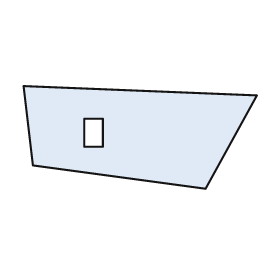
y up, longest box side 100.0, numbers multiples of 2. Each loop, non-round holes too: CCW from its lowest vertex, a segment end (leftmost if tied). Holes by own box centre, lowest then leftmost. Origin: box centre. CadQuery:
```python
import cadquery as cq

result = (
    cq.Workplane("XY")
    .moveTo(28.0, -22.0)
    .lineTo(50.0, 18.0)
    .lineTo(-50.0, 22.0)
    .lineTo(-46.0, -12.0)
    .close()
    .moveTo(-24.0, -4.0)
    .lineTo(-16.0, -4.0)
    .lineTo(-16.0, 8.0)
    .lineTo(-24.0, 8.0)
    .close()
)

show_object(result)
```